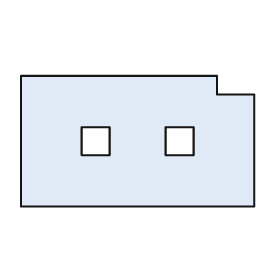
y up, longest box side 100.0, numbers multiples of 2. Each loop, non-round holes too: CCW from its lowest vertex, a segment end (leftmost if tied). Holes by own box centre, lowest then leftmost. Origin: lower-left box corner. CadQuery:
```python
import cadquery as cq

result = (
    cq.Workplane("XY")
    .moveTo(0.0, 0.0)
    .lineTo(100.0, 0.0)
    .lineTo(100.0, 48.0)
    .lineTo(84.0, 48.0)
    .lineTo(84.0, 56.0)
    .lineTo(0.0, 56.0)
    .close()
    .moveTo(26.0, 22.0)
    .lineTo(38.0, 22.0)
    .lineTo(38.0, 34.0)
    .lineTo(26.0, 34.0)
    .close()
    .moveTo(62.0, 22.0)
    .lineTo(74.0, 22.0)
    .lineTo(74.0, 34.0)
    .lineTo(62.0, 34.0)
    .close()
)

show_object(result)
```